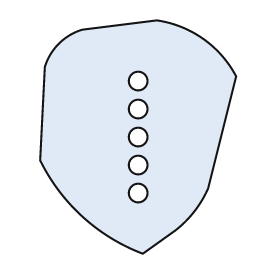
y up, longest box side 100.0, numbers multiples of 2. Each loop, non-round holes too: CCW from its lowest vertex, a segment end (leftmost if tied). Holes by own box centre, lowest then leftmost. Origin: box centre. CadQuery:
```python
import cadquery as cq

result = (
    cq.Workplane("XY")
    .moveTo(2.0, -50.0)
    .lineTo(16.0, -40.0)
    .threePointArc((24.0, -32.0), (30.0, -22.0))
    .lineTo(42.0, 26.0)
    .threePointArc((28.0, 42.0), (8.0, 50.0))
    .lineTo(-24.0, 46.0)
    .threePointArc((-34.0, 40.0), (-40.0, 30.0))
    .lineTo(-42.0, -10.0)
    .threePointArc((-24.0, -34.0), (2.0, -50.0))
    .close()
    .moveTo(0.0, -24.0)
    .circle(4.0)
    .moveTo(0.0, -12.0)
    .circle(4.0)
    .moveTo(0.0, 0.0)
    .circle(4.0)
    .moveTo(0.0, 12.0)
    .circle(4.0)
    .moveTo(0.0, 24.0)
    .circle(4.0)
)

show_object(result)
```